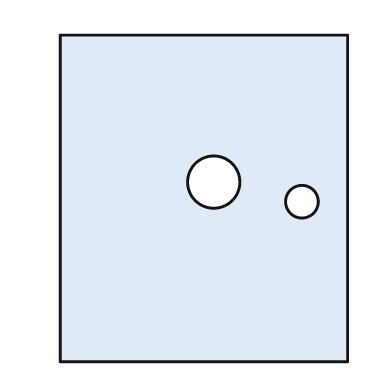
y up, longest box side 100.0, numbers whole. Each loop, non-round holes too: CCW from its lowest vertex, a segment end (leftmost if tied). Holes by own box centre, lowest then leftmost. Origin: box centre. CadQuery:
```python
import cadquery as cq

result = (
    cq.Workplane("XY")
    .moveTo(-44.0, -50.0)
    .lineTo(44.0, -50.0)
    .lineTo(44.0, 50.0)
    .lineTo(-44.0, 50.0)
    .close()
    .moveTo(30.0, -1.0)
    .circle(5.0)
    .moveTo(3.0, 5.0)
    .circle(8.0)
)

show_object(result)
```